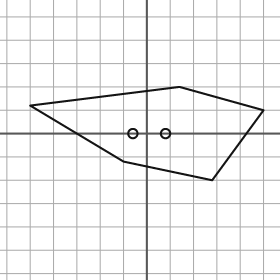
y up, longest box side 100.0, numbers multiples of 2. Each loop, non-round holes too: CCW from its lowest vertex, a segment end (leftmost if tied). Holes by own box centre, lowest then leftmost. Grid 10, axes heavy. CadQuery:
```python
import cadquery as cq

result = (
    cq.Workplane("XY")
    .moveTo(28.0, -20.0)
    .lineTo(50.0, 10.0)
    .lineTo(14.0, 20.0)
    .lineTo(-50.0, 12.0)
    .lineTo(-10.0, -12.0)
    .close()
    .moveTo(-6.0, 0.0)
    .circle(2.0)
    .moveTo(8.0, 0.0)
    .circle(2.0)
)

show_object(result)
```